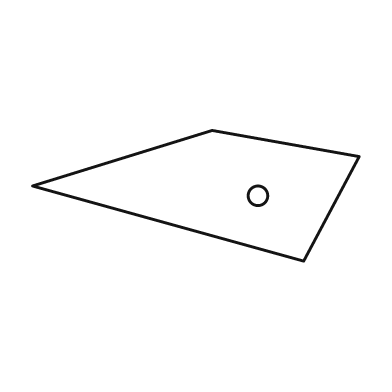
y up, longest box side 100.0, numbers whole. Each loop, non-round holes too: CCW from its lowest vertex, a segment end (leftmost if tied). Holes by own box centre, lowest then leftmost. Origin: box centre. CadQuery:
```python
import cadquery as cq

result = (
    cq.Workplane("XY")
    .moveTo(33.0, -20.0)
    .lineTo(50.0, 12.0)
    .lineTo(5.0, 20.0)
    .lineTo(-50.0, 3.0)
    .close()
    .moveTo(19.0, 0.0)
    .circle(3.0)
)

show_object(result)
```